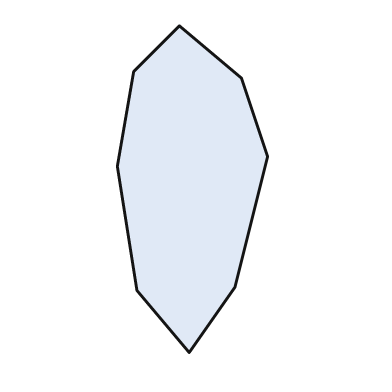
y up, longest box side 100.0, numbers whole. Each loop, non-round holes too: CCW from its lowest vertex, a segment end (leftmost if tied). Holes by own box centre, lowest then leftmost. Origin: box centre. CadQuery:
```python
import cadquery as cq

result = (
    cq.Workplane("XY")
    .moveTo(-1.0, -50.0)
    .lineTo(13.0, -30.0)
    .lineTo(23.0, 10.0)
    .lineTo(15.0, 34.0)
    .lineTo(-4.0, 50.0)
    .lineTo(-18.0, 36.0)
    .lineTo(-23.0, 7.0)
    .lineTo(-17.0, -31.0)
    .close()
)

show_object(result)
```